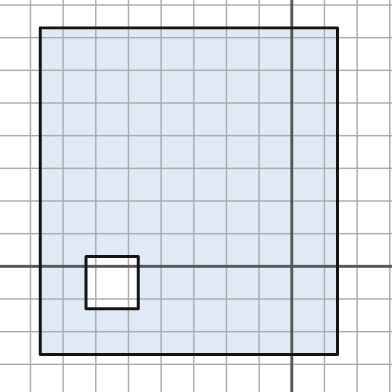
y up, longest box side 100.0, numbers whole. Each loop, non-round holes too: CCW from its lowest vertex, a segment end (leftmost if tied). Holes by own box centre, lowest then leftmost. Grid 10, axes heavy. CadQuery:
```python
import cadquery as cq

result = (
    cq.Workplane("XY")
    .moveTo(-77.0, -27.0)
    .lineTo(14.0, -27.0)
    .lineTo(14.0, 73.0)
    .lineTo(-77.0, 73.0)
    .close()
    .moveTo(-63.0, -13.0)
    .lineTo(-47.0, -13.0)
    .lineTo(-47.0, 3.0)
    .lineTo(-63.0, 3.0)
    .close()
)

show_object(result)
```